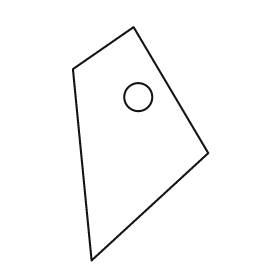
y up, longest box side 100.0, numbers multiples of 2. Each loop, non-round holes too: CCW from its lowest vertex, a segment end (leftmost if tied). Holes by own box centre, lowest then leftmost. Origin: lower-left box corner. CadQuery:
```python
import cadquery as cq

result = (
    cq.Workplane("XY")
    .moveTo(8.0, 0.0)
    .lineTo(58.0, 46.0)
    .lineTo(26.0, 100.0)
    .lineTo(0.0, 82.0)
    .close()
    .moveTo(28.0, 70.0)
    .circle(6.0)
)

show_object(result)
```